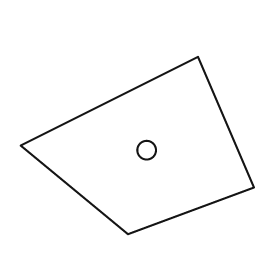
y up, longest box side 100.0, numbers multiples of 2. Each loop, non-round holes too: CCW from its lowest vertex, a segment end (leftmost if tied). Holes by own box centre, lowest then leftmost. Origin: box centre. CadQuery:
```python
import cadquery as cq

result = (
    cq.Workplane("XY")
    .moveTo(-4.0, -38.0)
    .lineTo(50.0, -18.0)
    .lineTo(26.0, 38.0)
    .lineTo(-50.0, 0.0)
    .close()
    .moveTo(4.0, -2.0)
    .circle(4.0)
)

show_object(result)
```